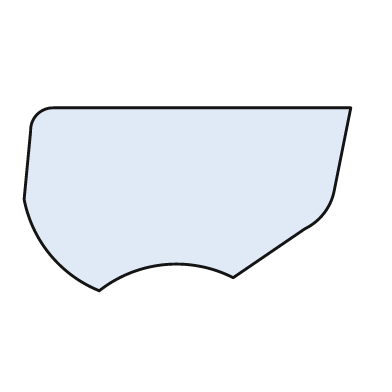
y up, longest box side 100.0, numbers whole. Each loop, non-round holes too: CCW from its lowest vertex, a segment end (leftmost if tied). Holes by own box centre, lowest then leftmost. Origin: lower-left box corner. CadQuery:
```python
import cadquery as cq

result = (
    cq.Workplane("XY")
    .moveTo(23.0, 0.0)
    .threePointArc((43.0, 8.0), (64.0, 4.0))
    .lineTo(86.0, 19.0)
    .threePointArc((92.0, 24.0), (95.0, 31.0))
    .lineTo(100.0, 56.0)
    .lineTo(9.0, 56.0)
    .threePointArc((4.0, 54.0), (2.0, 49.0))
    .lineTo(0.0, 28.0)
    .threePointArc((8.0, 11.0), (23.0, 0.0))
    .close()
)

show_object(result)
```